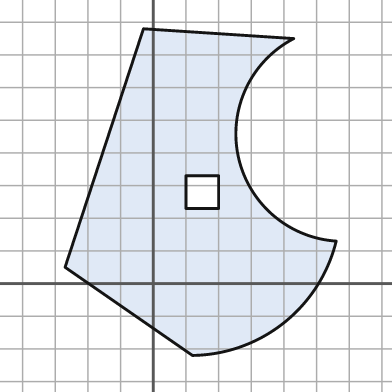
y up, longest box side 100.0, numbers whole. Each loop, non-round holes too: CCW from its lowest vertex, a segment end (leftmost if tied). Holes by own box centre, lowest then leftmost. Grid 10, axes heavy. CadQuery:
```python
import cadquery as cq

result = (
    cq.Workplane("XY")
    .moveTo(12.0, -22.0)
    .threePointArc((40.0, -12.0), (56.0, 13.0))
    .threePointArc((26.0, 39.0), (43.0, 75.0))
    .lineTo(-3.0, 78.0)
    .lineTo(-27.0, 5.0)
    .close()
    .moveTo(10.0, 23.0)
    .lineTo(20.0, 23.0)
    .lineTo(20.0, 33.0)
    .lineTo(10.0, 33.0)
    .close()
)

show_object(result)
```